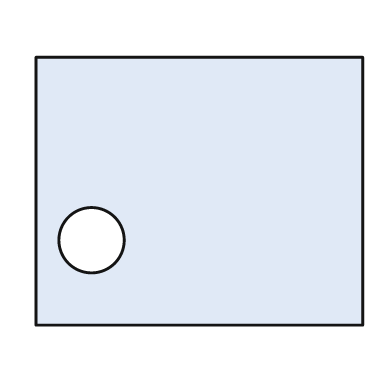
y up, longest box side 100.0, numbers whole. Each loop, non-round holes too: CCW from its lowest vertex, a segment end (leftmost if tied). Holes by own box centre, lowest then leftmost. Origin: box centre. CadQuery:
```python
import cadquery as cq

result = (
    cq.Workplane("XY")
    .moveTo(-50.0, -41.0)
    .lineTo(50.0, -41.0)
    .lineTo(50.0, 41.0)
    .lineTo(-50.0, 41.0)
    .close()
    .moveTo(-33.0, -15.0)
    .circle(10.0)
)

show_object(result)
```